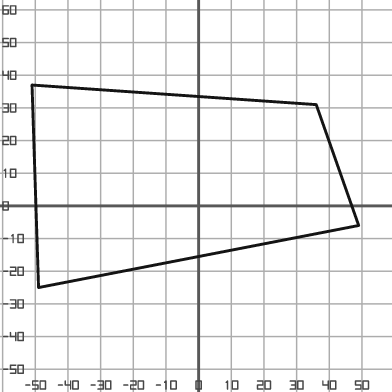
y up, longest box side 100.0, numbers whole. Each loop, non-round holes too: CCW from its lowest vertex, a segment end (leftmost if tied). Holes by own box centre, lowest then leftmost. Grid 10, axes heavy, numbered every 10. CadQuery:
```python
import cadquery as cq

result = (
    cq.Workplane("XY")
    .moveTo(-49.0, -25.0)
    .lineTo(49.0, -6.0)
    .lineTo(36.0, 31.0)
    .lineTo(-51.0, 37.0)
    .close()
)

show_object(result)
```